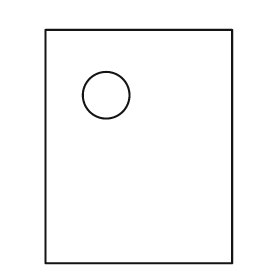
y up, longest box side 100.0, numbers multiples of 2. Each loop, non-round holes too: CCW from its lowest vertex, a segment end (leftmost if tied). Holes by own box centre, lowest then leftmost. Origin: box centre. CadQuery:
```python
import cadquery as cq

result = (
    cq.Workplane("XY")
    .moveTo(-40.0, -50.0)
    .lineTo(40.0, -50.0)
    .lineTo(40.0, 50.0)
    .lineTo(-40.0, 50.0)
    .close()
    .moveTo(-14.0, 22.0)
    .circle(10.0)
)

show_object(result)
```